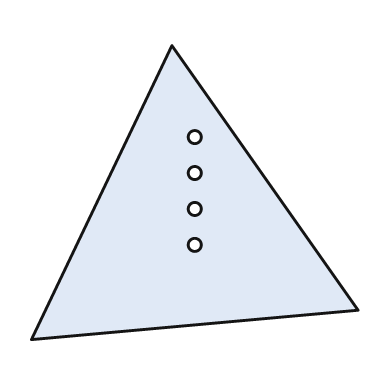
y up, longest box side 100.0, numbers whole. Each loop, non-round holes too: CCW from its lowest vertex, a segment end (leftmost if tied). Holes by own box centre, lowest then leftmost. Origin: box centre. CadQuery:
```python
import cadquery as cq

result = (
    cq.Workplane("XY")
    .moveTo(-50.0, -45.0)
    .lineTo(50.0, -36.0)
    .lineTo(-7.0, 45.0)
    .close()
    .moveTo(0.0, -16.0)
    .circle(2.0)
    .moveTo(0.0, -5.0)
    .circle(2.0)
    .moveTo(0.0, 6.0)
    .circle(2.0)
    .moveTo(0.0, 17.0)
    .circle(2.0)
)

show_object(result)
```